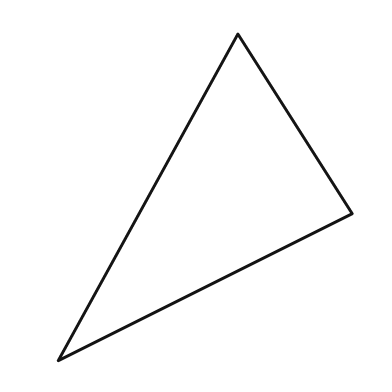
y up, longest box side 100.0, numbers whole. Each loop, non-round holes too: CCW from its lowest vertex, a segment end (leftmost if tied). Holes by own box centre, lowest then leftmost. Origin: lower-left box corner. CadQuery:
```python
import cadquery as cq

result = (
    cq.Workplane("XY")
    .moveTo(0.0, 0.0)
    .lineTo(90.0, 45.0)
    .lineTo(55.0, 100.0)
    .close()
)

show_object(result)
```